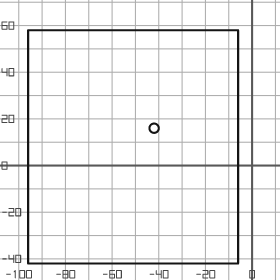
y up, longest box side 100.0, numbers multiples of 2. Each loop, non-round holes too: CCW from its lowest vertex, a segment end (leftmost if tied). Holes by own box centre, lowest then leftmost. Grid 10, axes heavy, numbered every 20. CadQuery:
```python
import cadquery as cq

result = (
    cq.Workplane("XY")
    .moveTo(-96.0, -42.0)
    .lineTo(-6.0, -42.0)
    .lineTo(-6.0, 58.0)
    .lineTo(-96.0, 58.0)
    .close()
    .moveTo(-42.0, 16.0)
    .circle(2.0)
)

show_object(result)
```